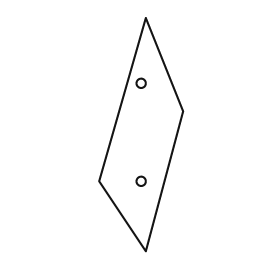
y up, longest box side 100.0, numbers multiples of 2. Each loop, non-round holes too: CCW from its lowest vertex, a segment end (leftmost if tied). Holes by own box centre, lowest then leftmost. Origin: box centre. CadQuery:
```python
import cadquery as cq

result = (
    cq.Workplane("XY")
    .moveTo(2.0, -50.0)
    .lineTo(18.0, 10.0)
    .lineTo(2.0, 50.0)
    .lineTo(-18.0, -20.0)
    .close()
    .moveTo(0.0, -20.0)
    .circle(2.0)
    .moveTo(0.0, 22.0)
    .circle(2.0)
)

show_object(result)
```